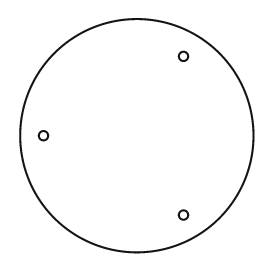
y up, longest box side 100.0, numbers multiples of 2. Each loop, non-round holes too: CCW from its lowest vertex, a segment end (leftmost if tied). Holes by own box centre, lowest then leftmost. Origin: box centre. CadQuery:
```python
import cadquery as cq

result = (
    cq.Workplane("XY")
    .moveTo(0.0, 0.0)
    .circle(50.0)
    .moveTo(20.0, -34.0)
    .circle(2.0)
    .moveTo(-40.0, 0.0)
    .circle(2.0)
    .moveTo(20.0, 34.0)
    .circle(2.0)
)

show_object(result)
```